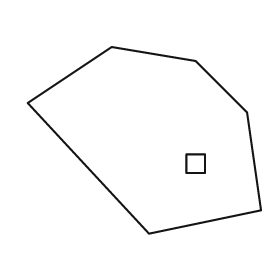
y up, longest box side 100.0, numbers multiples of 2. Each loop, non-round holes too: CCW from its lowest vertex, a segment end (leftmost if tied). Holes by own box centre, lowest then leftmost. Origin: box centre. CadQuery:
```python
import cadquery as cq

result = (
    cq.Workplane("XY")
    .moveTo(2.0, -40.0)
    .lineTo(50.0, -30.0)
    .lineTo(44.0, 12.0)
    .lineTo(22.0, 34.0)
    .lineTo(-14.0, 40.0)
    .lineTo(-50.0, 16.0)
    .close()
    .moveTo(18.0, -14.0)
    .lineTo(26.0, -14.0)
    .lineTo(26.0, -6.0)
    .lineTo(18.0, -6.0)
    .close()
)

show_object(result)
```